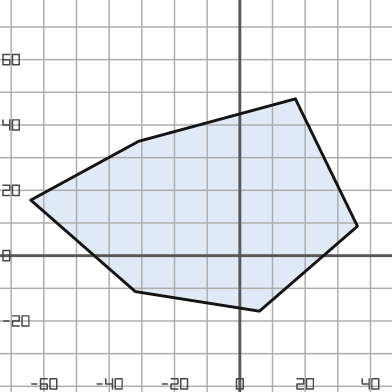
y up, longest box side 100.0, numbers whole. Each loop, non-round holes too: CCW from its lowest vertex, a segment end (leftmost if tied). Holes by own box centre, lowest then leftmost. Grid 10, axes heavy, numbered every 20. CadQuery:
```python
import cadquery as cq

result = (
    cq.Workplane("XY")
    .moveTo(6.0, -17.0)
    .lineTo(36.0, 9.0)
    .lineTo(17.0, 48.0)
    .lineTo(-31.0, 35.0)
    .lineTo(-64.0, 17.0)
    .lineTo(-32.0, -11.0)
    .close()
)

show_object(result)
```